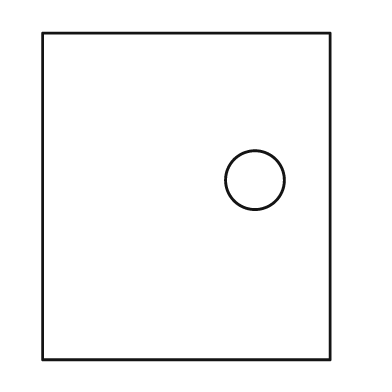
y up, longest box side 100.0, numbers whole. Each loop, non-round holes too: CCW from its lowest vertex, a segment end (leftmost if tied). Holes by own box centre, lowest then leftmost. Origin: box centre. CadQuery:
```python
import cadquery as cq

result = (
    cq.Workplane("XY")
    .moveTo(-44.0, -50.0)
    .lineTo(44.0, -50.0)
    .lineTo(44.0, 50.0)
    .lineTo(-44.0, 50.0)
    .close()
    .moveTo(21.0, 5.0)
    .circle(9.0)
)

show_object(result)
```